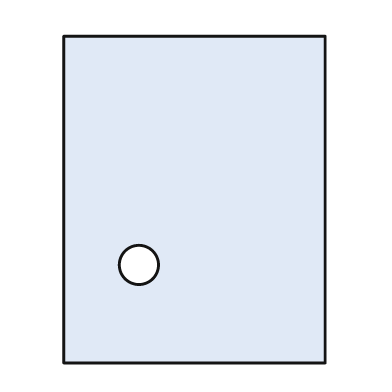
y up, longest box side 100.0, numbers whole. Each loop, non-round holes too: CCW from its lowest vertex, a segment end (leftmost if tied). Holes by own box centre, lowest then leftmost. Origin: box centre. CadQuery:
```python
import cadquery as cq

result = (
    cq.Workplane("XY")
    .moveTo(-40.0, -50.0)
    .lineTo(40.0, -50.0)
    .lineTo(40.0, 50.0)
    .lineTo(-40.0, 50.0)
    .close()
    .moveTo(-17.0, -20.0)
    .circle(6.0)
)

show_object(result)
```